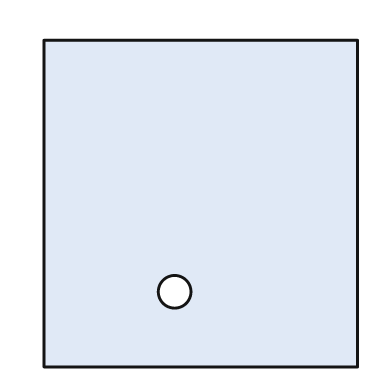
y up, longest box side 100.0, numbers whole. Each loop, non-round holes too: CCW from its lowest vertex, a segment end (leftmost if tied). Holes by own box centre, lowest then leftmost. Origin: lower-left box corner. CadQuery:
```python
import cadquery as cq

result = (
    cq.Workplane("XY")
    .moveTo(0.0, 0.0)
    .lineTo(96.0, 0.0)
    .lineTo(96.0, 100.0)
    .lineTo(0.0, 100.0)
    .close()
    .moveTo(40.0, 23.0)
    .circle(5.0)
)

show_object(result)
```